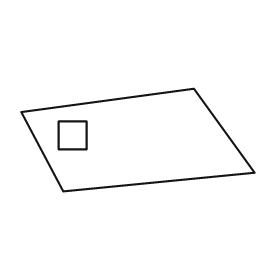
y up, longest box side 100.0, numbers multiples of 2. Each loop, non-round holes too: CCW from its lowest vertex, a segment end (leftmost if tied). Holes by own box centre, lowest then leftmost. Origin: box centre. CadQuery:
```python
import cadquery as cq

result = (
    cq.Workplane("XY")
    .moveTo(-32.0, -22.0)
    .lineTo(50.0, -14.0)
    .lineTo(24.0, 22.0)
    .lineTo(-50.0, 12.0)
    .close()
    .moveTo(-34.0, -4.0)
    .lineTo(-22.0, -4.0)
    .lineTo(-22.0, 8.0)
    .lineTo(-34.0, 8.0)
    .close()
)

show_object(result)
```